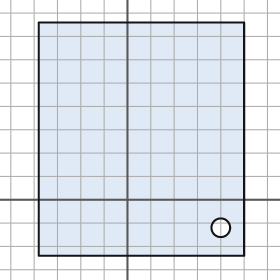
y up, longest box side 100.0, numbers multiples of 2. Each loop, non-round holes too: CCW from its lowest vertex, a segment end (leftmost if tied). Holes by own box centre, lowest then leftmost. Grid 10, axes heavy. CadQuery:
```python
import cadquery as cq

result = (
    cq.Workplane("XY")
    .moveTo(-38.0, -24.0)
    .lineTo(50.0, -24.0)
    .lineTo(50.0, 76.0)
    .lineTo(-38.0, 76.0)
    .close()
    .moveTo(40.0, -12.0)
    .circle(4.0)
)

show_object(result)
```